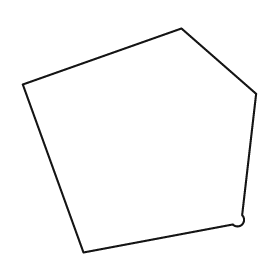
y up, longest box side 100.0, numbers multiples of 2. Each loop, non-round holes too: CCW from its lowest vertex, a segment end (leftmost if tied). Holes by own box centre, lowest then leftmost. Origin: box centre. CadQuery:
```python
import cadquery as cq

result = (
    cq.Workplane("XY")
    .moveTo(-24.0, -48.0)
    .lineTo(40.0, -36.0)
    .threePointArc((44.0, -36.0), (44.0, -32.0))
    .lineTo(50.0, 20.0)
    .lineTo(18.0, 48.0)
    .lineTo(-50.0, 24.0)
    .close()
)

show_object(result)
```